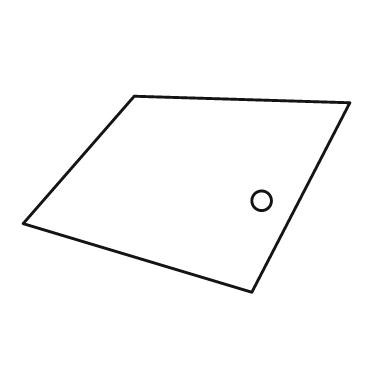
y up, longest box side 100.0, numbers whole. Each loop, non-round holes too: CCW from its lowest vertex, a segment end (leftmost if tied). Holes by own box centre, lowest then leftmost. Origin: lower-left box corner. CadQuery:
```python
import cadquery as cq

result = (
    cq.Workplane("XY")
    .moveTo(70.0, 0.0)
    .lineTo(100.0, 58.0)
    .lineTo(34.0, 60.0)
    .lineTo(0.0, 21.0)
    .close()
    .moveTo(73.0, 28.0)
    .circle(3.0)
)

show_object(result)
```